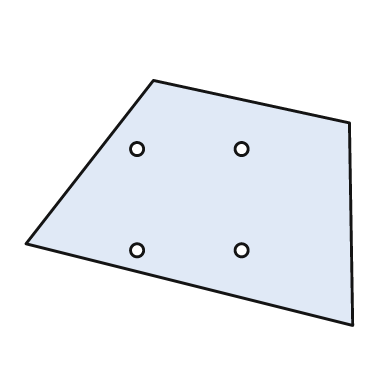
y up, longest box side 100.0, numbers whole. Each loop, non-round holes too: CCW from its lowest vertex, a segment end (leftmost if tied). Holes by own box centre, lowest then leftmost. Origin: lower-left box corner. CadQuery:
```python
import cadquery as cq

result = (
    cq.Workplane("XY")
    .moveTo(100.0, 0.0)
    .lineTo(99.0, 62.0)
    .lineTo(39.0, 75.0)
    .lineTo(0.0, 25.0)
    .close()
    .moveTo(34.0, 23.0)
    .circle(2.0)
    .moveTo(66.0, 23.0)
    .circle(2.0)
    .moveTo(34.0, 54.0)
    .circle(2.0)
    .moveTo(66.0, 54.0)
    .circle(2.0)
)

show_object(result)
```